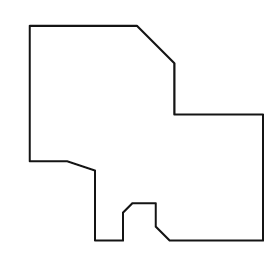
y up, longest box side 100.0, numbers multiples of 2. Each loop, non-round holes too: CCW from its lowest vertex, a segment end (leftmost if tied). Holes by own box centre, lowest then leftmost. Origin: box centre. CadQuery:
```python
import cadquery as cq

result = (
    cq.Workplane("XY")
    .moveTo(-22.0, -46.0)
    .lineTo(-10.0, -46.0)
    .lineTo(-10.0, -34.0)
    .lineTo(-6.0, -30.0)
    .lineTo(4.0, -30.0)
    .lineTo(4.0, -40.0)
    .lineTo(10.0, -46.0)
    .lineTo(50.0, -46.0)
    .lineTo(50.0, 8.0)
    .lineTo(12.0, 8.0)
    .lineTo(12.0, 30.0)
    .lineTo(-4.0, 46.0)
    .lineTo(-50.0, 46.0)
    .lineTo(-50.0, -12.0)
    .lineTo(-34.0, -12.0)
    .lineTo(-22.0, -16.0)
    .close()
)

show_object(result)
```